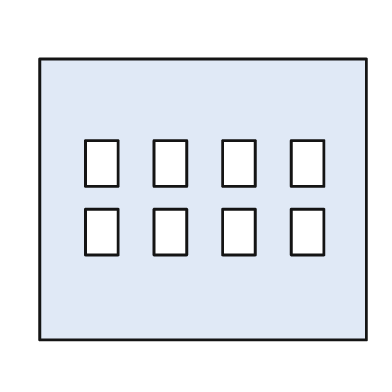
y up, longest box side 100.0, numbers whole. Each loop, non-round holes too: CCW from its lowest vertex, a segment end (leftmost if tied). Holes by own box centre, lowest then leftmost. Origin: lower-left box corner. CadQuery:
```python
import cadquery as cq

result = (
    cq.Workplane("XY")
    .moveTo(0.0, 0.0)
    .lineTo(100.0, 0.0)
    .lineTo(100.0, 86.0)
    .lineTo(0.0, 86.0)
    .close()
    .moveTo(14.0, 26.0)
    .lineTo(24.0, 26.0)
    .lineTo(24.0, 40.0)
    .lineTo(14.0, 40.0)
    .close()
    .moveTo(35.0, 26.0)
    .lineTo(45.0, 26.0)
    .lineTo(45.0, 40.0)
    .lineTo(35.0, 40.0)
    .close()
    .moveTo(56.0, 26.0)
    .lineTo(66.0, 26.0)
    .lineTo(66.0, 40.0)
    .lineTo(56.0, 40.0)
    .close()
    .moveTo(77.0, 26.0)
    .lineTo(87.0, 26.0)
    .lineTo(87.0, 40.0)
    .lineTo(77.0, 40.0)
    .close()
    .moveTo(14.0, 47.0)
    .lineTo(24.0, 47.0)
    .lineTo(24.0, 61.0)
    .lineTo(14.0, 61.0)
    .close()
    .moveTo(35.0, 47.0)
    .lineTo(45.0, 47.0)
    .lineTo(45.0, 61.0)
    .lineTo(35.0, 61.0)
    .close()
    .moveTo(56.0, 47.0)
    .lineTo(66.0, 47.0)
    .lineTo(66.0, 61.0)
    .lineTo(56.0, 61.0)
    .close()
    .moveTo(77.0, 47.0)
    .lineTo(87.0, 47.0)
    .lineTo(87.0, 61.0)
    .lineTo(77.0, 61.0)
    .close()
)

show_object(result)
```